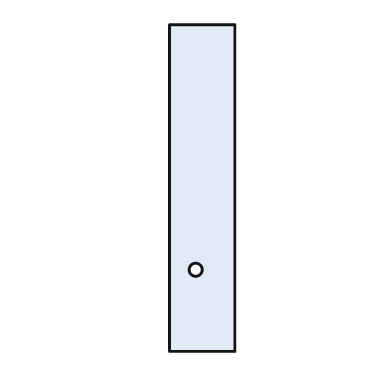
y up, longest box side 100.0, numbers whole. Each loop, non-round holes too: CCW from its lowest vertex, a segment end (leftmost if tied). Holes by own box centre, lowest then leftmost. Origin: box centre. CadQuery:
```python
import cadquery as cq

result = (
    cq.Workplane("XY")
    .moveTo(-10.0, -50.0)
    .lineTo(10.0, -50.0)
    .lineTo(10.0, 50.0)
    .lineTo(-10.0, 50.0)
    .close()
    .moveTo(-2.0, -25.0)
    .circle(2.0)
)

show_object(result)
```